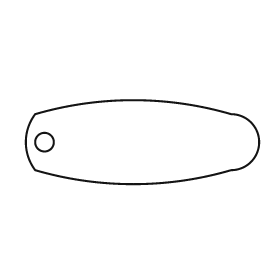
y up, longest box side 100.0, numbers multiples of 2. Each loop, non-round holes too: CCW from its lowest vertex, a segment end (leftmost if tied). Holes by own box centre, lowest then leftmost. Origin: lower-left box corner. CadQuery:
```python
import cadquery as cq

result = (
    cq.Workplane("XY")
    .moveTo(4.0, 6.0)
    .threePointArc((46.0, 0.0), (88.0, 6.0))
    .threePointArc((100.0, 18.0), (88.0, 30.0))
    .threePointArc((46.0, 36.0), (4.0, 30.0))
    .threePointArc((0.0, 18.0), (4.0, 6.0))
    .close()
    .moveTo(8.0, 18.0)
    .circle(4.0)
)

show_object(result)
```